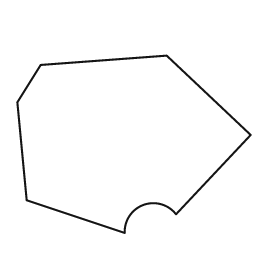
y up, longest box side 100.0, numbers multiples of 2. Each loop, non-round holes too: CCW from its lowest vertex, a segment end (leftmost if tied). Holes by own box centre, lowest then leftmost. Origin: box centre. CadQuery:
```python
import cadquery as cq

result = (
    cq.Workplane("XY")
    .moveTo(-4.0, -38.0)
    .threePointArc((4.0, -26.0), (18.0, -30.0))
    .lineTo(50.0, 4.0)
    .lineTo(14.0, 38.0)
    .lineTo(-40.0, 34.0)
    .lineTo(-50.0, 18.0)
    .lineTo(-46.0, -24.0)
    .close()
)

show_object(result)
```